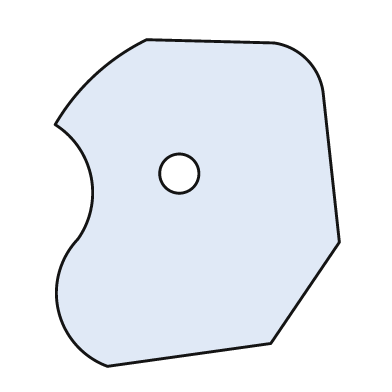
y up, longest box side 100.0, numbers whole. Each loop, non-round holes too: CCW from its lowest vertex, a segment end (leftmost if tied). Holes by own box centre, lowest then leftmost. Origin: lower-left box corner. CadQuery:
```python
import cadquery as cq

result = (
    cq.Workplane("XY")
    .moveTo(16.0, 0.0)
    .lineTo(66.0, 7.0)
    .lineTo(87.0, 38.0)
    .lineTo(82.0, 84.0)
    .threePointArc((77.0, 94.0), (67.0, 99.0))
    .lineTo(28.0, 100.0)
    .threePointArc((12.0, 89.0), (0.0, 74.0))
    .threePointArc((11.0, 58.0), (7.0, 39.0))
    .threePointArc((1.0, 17.0), (16.0, 0.0))
    .close()
    .moveTo(38.0, 59.0)
    .circle(6.0)
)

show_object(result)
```